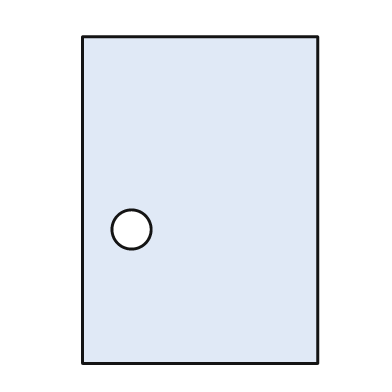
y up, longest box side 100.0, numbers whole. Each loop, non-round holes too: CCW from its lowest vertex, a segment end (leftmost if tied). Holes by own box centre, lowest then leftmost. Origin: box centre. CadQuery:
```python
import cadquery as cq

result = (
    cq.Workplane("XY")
    .moveTo(-36.0, -50.0)
    .lineTo(36.0, -50.0)
    .lineTo(36.0, 50.0)
    .lineTo(-36.0, 50.0)
    .close()
    .moveTo(-21.0, -9.0)
    .circle(6.0)
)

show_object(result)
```